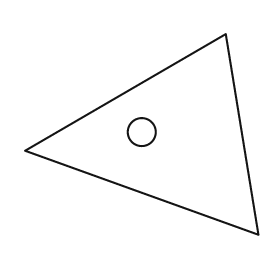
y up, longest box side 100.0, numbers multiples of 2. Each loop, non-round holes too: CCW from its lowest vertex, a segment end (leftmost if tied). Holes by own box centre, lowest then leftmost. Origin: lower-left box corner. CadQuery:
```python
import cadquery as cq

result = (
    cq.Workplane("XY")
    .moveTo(100.0, 0.0)
    .lineTo(86.0, 86.0)
    .lineTo(0.0, 36.0)
    .close()
    .moveTo(50.0, 44.0)
    .circle(6.0)
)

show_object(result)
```